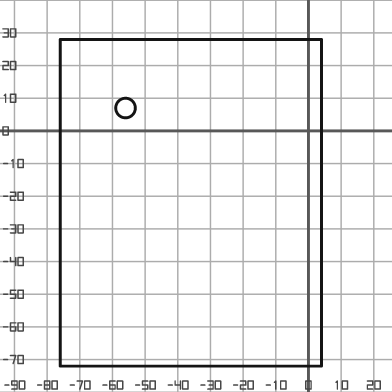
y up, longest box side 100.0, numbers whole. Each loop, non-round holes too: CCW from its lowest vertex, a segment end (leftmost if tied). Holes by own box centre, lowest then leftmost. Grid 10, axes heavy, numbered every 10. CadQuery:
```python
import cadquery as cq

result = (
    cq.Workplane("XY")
    .moveTo(-76.0, -72.0)
    .lineTo(4.0, -72.0)
    .lineTo(4.0, 28.0)
    .lineTo(-76.0, 28.0)
    .close()
    .moveTo(-56.0, 7.0)
    .circle(3.0)
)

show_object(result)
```